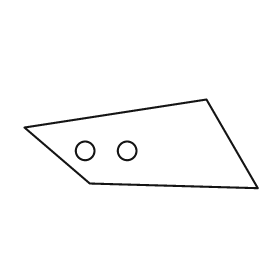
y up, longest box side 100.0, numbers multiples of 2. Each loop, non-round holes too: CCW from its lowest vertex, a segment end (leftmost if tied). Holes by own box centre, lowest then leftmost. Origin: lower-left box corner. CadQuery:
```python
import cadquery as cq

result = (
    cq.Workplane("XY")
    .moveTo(100.0, 0.0)
    .lineTo(78.0, 38.0)
    .lineTo(0.0, 26.0)
    .lineTo(28.0, 2.0)
    .close()
    .moveTo(26.0, 16.0)
    .circle(4.0)
    .moveTo(44.0, 16.0)
    .circle(4.0)
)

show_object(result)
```